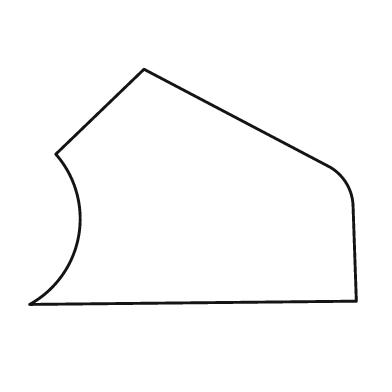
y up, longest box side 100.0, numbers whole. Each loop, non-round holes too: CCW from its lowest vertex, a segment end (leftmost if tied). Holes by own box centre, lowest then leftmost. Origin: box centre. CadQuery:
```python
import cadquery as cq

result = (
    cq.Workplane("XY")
    .moveTo(-50.0, -36.0)
    .lineTo(50.0, -35.0)
    .lineTo(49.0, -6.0)
    .threePointArc((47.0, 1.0), (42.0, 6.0))
    .lineTo(-15.0, 36.0)
    .lineTo(-42.0, 10.0)
    .threePointArc((-35.0, -15.0), (-50.0, -36.0))
    .close()
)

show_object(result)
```